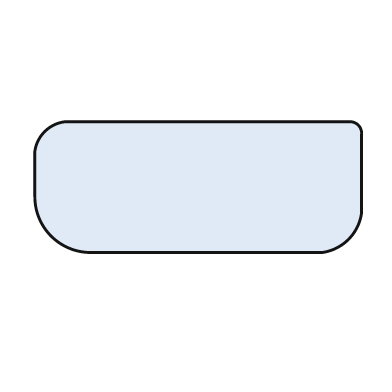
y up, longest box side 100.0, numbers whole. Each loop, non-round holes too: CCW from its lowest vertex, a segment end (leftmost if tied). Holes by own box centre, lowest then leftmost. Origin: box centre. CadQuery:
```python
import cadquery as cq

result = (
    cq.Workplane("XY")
    .moveTo(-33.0, -20.0)
    .lineTo(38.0, -20.0)
    .threePointArc((46.0, -16.0), (50.0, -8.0))
    .lineTo(50.0, 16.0)
    .threePointArc((49.0, 19.0), (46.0, 20.0))
    .lineTo(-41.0, 20.0)
    .threePointArc((-47.0, 17.0), (-50.0, 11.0))
    .lineTo(-50.0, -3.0)
    .threePointArc((-45.0, -15.0), (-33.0, -20.0))
    .close()
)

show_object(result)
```